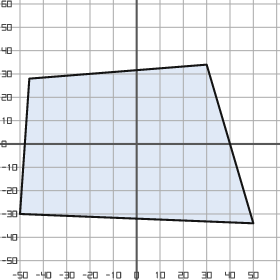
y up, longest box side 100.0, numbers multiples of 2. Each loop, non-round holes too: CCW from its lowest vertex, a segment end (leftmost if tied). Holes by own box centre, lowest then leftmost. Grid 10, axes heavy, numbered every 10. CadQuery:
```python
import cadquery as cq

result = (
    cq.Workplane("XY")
    .moveTo(50.0, -34.0)
    .lineTo(30.0, 34.0)
    .lineTo(-46.0, 28.0)
    .lineTo(-50.0, -30.0)
    .close()
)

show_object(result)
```